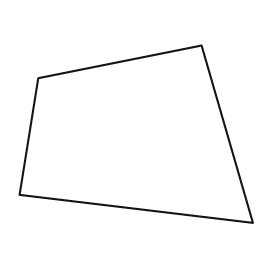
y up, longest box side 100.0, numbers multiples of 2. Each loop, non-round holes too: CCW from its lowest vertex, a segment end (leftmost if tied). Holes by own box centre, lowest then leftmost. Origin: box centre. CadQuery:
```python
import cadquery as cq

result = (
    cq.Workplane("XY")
    .moveTo(50.0, -38.0)
    .lineTo(28.0, 38.0)
    .lineTo(-42.0, 24.0)
    .lineTo(-50.0, -26.0)
    .close()
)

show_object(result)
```